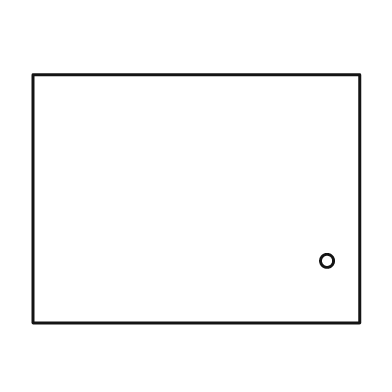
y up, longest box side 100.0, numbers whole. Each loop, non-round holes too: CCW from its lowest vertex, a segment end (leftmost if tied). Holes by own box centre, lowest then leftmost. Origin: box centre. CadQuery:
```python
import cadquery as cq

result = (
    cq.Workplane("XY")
    .moveTo(-50.0, -38.0)
    .lineTo(50.0, -38.0)
    .lineTo(50.0, 38.0)
    .lineTo(-50.0, 38.0)
    .close()
    .moveTo(40.0, -19.0)
    .circle(2.0)
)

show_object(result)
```